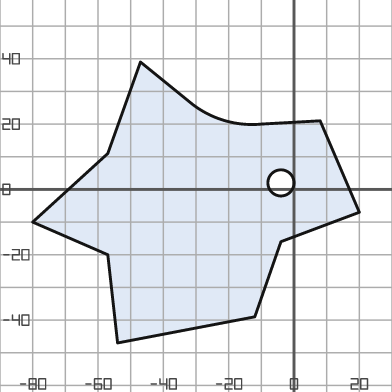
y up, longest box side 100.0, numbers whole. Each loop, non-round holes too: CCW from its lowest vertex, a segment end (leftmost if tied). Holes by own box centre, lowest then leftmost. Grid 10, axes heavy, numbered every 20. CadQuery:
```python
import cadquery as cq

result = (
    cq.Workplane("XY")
    .moveTo(-54.0, -47.0)
    .lineTo(-12.0, -39.0)
    .lineTo(-4.0, -16.0)
    .lineTo(20.0, -7.0)
    .lineTo(8.0, 21.0)
    .lineTo(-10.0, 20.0)
    .threePointArc((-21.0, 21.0), (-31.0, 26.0))
    .lineTo(-47.0, 39.0)
    .lineTo(-57.0, 11.0)
    .lineTo(-80.0, -10.0)
    .lineTo(-57.0, -20.0)
    .close()
    .moveTo(-4.0, 2.0)
    .circle(4.0)
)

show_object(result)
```